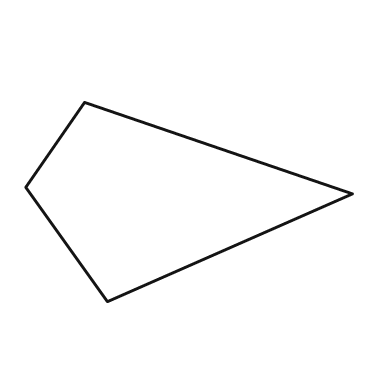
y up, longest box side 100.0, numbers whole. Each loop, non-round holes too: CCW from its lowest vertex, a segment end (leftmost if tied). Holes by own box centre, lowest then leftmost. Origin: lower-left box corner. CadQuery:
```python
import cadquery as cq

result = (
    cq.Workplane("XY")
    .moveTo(25.0, 0.0)
    .lineTo(100.0, 33.0)
    .lineTo(18.0, 61.0)
    .lineTo(0.0, 35.0)
    .close()
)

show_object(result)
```